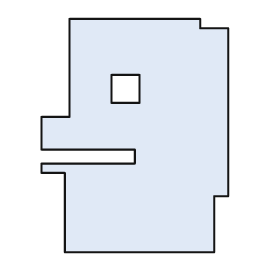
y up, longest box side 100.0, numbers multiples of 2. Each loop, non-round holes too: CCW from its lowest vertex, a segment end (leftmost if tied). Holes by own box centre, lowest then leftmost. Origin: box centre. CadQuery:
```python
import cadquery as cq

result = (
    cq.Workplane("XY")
    .moveTo(-30.0, -50.0)
    .lineTo(34.0, -50.0)
    .lineTo(34.0, -26.0)
    .lineTo(40.0, -26.0)
    .lineTo(40.0, 46.0)
    .lineTo(28.0, 46.0)
    .lineTo(28.0, 50.0)
    .lineTo(-28.0, 50.0)
    .lineTo(-28.0, 8.0)
    .lineTo(-40.0, 8.0)
    .lineTo(-40.0, -6.0)
    .lineTo(0.0, -6.0)
    .lineTo(0.0, -12.0)
    .lineTo(-40.0, -12.0)
    .lineTo(-40.0, -16.0)
    .lineTo(-30.0, -16.0)
    .close()
    .moveTo(-10.0, 14.0)
    .lineTo(2.0, 14.0)
    .lineTo(2.0, 26.0)
    .lineTo(-10.0, 26.0)
    .close()
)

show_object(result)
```